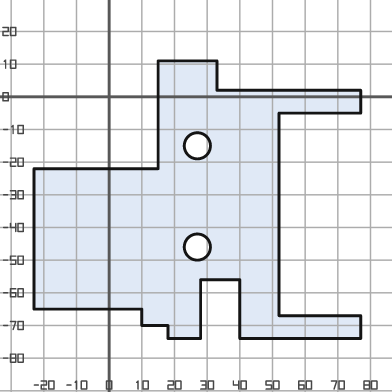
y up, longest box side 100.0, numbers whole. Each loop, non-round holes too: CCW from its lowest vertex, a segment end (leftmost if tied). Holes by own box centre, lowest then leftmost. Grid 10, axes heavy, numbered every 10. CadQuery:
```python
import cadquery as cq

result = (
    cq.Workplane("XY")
    .moveTo(18.0, -74.0)
    .lineTo(28.0, -74.0)
    .lineTo(28.0, -56.0)
    .lineTo(40.0, -56.0)
    .lineTo(40.0, -74.0)
    .lineTo(77.0, -74.0)
    .lineTo(77.0, -67.0)
    .lineTo(52.0, -67.0)
    .lineTo(52.0, -5.0)
    .lineTo(77.0, -5.0)
    .lineTo(77.0, 2.0)
    .lineTo(33.0, 2.0)
    .lineTo(33.0, 11.0)
    .lineTo(15.0, 11.0)
    .lineTo(15.0, -22.0)
    .lineTo(-23.0, -22.0)
    .lineTo(-23.0, -65.0)
    .lineTo(10.0, -65.0)
    .lineTo(10.0, -70.0)
    .lineTo(18.0, -70.0)
    .close()
    .moveTo(27.0, -46.0)
    .circle(4.0)
    .moveTo(27.0, -15.0)
    .circle(4.0)
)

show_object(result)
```